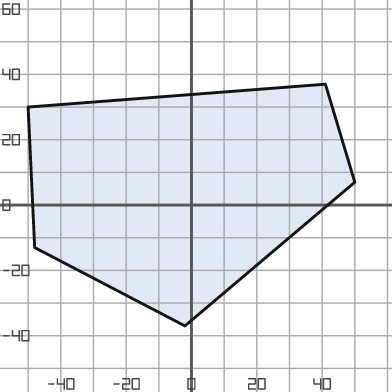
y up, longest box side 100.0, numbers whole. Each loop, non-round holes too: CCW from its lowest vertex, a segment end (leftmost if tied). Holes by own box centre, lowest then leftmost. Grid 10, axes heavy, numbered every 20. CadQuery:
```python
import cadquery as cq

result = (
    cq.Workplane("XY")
    .moveTo(-2.0, -37.0)
    .lineTo(50.0, 7.0)
    .lineTo(41.0, 37.0)
    .lineTo(-50.0, 30.0)
    .lineTo(-48.0, -13.0)
    .close()
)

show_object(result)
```